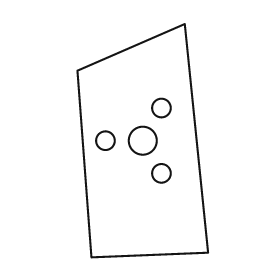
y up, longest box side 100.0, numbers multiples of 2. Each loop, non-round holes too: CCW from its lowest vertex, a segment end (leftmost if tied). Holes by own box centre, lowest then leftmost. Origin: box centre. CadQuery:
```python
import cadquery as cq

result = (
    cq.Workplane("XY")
    .moveTo(-22.0, -50.0)
    .lineTo(28.0, -48.0)
    .lineTo(18.0, 50.0)
    .lineTo(-28.0, 30.0)
    .close()
    .moveTo(8.0, -14.0)
    .circle(4.0)
    .moveTo(-16.0, 0.0)
    .circle(4.0)
    .moveTo(0.0, 0.0)
    .circle(6.0)
    .moveTo(8.0, 14.0)
    .circle(4.0)
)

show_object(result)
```